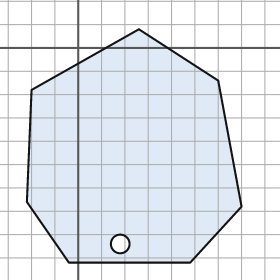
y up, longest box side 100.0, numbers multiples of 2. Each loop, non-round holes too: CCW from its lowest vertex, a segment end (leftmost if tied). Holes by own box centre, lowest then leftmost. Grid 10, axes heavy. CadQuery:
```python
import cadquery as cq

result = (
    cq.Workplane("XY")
    .moveTo(-4.0, -92.0)
    .lineTo(48.0, -92.0)
    .lineTo(70.0, -68.0)
    .lineTo(60.0, -14.0)
    .lineTo(26.0, 8.0)
    .lineTo(-20.0, -18.0)
    .lineTo(-22.0, -66.0)
    .close()
    .moveTo(18.0, -84.0)
    .circle(4.0)
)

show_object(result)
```